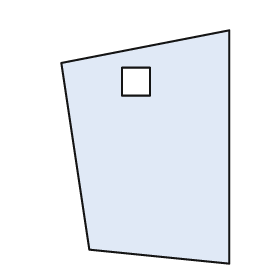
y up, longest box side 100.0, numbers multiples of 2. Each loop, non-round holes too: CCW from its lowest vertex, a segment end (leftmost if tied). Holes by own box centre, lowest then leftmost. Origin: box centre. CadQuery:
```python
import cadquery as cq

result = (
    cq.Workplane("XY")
    .moveTo(36.0, -50.0)
    .lineTo(36.0, 50.0)
    .lineTo(-36.0, 36.0)
    .lineTo(-24.0, -44.0)
    .close()
    .moveTo(-10.0, 22.0)
    .lineTo(2.0, 22.0)
    .lineTo(2.0, 34.0)
    .lineTo(-10.0, 34.0)
    .close()
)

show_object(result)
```